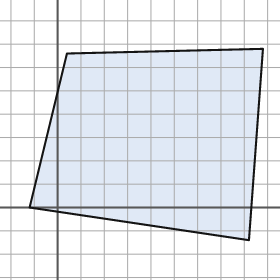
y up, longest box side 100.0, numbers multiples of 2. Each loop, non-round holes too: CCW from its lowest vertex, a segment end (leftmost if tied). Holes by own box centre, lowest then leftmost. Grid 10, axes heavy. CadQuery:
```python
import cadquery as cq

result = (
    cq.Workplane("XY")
    .moveTo(82.0, -14.0)
    .lineTo(88.0, 68.0)
    .lineTo(4.0, 66.0)
    .lineTo(-12.0, 0.0)
    .close()
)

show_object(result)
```